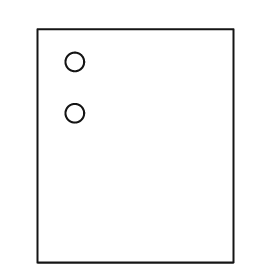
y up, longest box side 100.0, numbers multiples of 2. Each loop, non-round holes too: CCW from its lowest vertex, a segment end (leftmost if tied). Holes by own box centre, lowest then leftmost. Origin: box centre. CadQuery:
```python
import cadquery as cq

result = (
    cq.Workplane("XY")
    .moveTo(-42.0, -50.0)
    .lineTo(42.0, -50.0)
    .lineTo(42.0, 50.0)
    .lineTo(-42.0, 50.0)
    .close()
    .moveTo(-26.0, 14.0)
    .circle(4.0)
    .moveTo(-26.0, 36.0)
    .circle(4.0)
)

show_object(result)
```